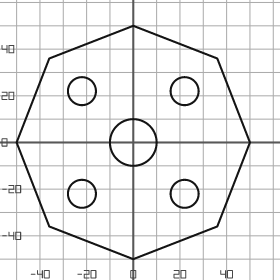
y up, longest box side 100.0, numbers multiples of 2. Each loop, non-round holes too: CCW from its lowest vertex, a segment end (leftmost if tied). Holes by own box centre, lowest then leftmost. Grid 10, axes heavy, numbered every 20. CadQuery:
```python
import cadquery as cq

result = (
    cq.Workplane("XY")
    .moveTo(0.0, -50.0)
    .lineTo(36.0, -36.0)
    .lineTo(50.0, 0.0)
    .lineTo(36.0, 36.0)
    .lineTo(0.0, 50.0)
    .lineTo(-36.0, 36.0)
    .lineTo(-50.0, 0.0)
    .lineTo(-36.0, -36.0)
    .close()
    .moveTo(-22.0, -22.0)
    .circle(6.0)
    .moveTo(22.0, -22.0)
    .circle(6.0)
    .moveTo(0.0, 0.0)
    .circle(10.0)
    .moveTo(-22.0, 22.0)
    .circle(6.0)
    .moveTo(22.0, 22.0)
    .circle(6.0)
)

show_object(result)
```